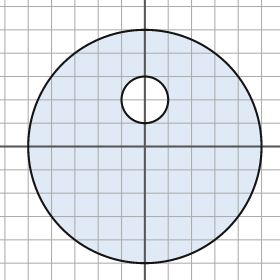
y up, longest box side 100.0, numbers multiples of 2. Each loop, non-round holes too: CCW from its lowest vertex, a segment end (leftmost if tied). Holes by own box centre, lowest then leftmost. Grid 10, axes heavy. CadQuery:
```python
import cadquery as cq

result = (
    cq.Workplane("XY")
    .moveTo(0.0, 0.0)
    .circle(50.0)
    .moveTo(0.0, 20.0)
    .circle(10.0)
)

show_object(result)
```